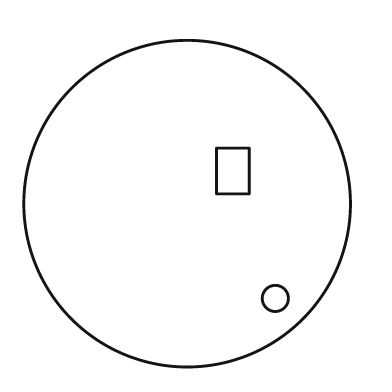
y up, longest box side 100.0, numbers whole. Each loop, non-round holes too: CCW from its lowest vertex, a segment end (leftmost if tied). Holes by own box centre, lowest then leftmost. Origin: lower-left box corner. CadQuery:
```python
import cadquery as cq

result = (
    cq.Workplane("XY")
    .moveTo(50.0, 50.0)
    .circle(50.0)
    .moveTo(77.0, 21.0)
    .circle(4.0)
    .moveTo(59.0, 53.0)
    .lineTo(69.0, 53.0)
    .lineTo(69.0, 67.0)
    .lineTo(59.0, 67.0)
    .close()
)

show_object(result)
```